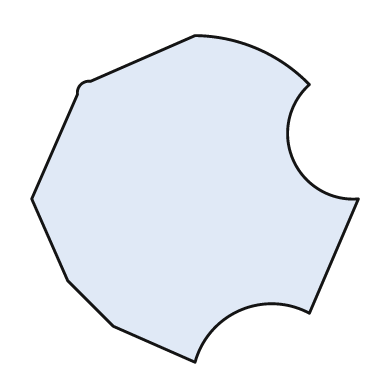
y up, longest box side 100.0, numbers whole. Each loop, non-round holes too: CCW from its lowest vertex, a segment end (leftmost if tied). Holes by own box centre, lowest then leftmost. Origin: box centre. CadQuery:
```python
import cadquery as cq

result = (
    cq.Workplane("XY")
    .moveTo(0.0, -50.0)
    .threePointArc((14.0, -34.0), (35.0, -35.0))
    .lineTo(50.0, 0.0)
    .threePointArc((30.0, 12.0), (35.0, 35.0))
    .threePointArc((19.0, 46.0), (0.0, 50.0))
    .lineTo(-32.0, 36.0)
    .threePointArc((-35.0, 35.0), (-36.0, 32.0))
    .lineTo(-50.0, 0.0)
    .lineTo(-39.0, -25.0)
    .lineTo(-25.0, -39.0)
    .close()
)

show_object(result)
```